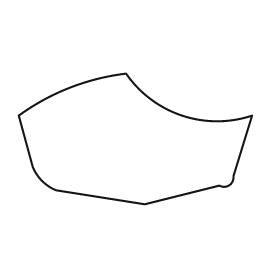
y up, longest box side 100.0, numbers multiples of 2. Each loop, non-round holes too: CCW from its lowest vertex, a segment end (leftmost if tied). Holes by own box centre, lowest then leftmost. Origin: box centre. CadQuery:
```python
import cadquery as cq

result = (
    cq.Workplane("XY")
    .moveTo(4.0, -28.0)
    .lineTo(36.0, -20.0)
    .threePointArc((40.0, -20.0), (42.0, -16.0))
    .lineTo(50.0, 10.0)
    .threePointArc((20.0, 10.0), (-4.0, 28.0))
    .threePointArc((-28.0, 22.0), (-50.0, 10.0))
    .lineTo(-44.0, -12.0)
    .threePointArc((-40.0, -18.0), (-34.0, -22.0))
    .close()
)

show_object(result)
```